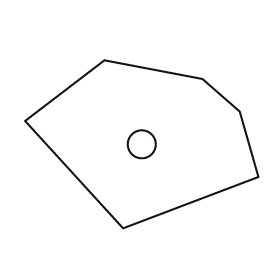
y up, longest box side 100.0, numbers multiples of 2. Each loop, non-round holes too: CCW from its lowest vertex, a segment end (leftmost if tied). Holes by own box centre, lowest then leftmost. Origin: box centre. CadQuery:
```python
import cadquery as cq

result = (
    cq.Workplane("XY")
    .moveTo(-8.0, -36.0)
    .lineTo(50.0, -14.0)
    .lineTo(42.0, 14.0)
    .lineTo(26.0, 28.0)
    .lineTo(-16.0, 36.0)
    .lineTo(-50.0, 10.0)
    .close()
    .moveTo(0.0, 0.0)
    .circle(6.0)
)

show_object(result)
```